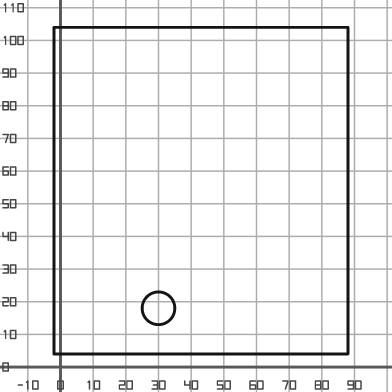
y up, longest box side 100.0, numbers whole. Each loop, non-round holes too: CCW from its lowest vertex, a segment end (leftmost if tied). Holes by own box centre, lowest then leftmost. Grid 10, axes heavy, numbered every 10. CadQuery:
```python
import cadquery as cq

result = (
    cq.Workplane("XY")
    .moveTo(-2.0, 4.0)
    .lineTo(88.0, 4.0)
    .lineTo(88.0, 104.0)
    .lineTo(-2.0, 104.0)
    .close()
    .moveTo(30.0, 18.0)
    .circle(5.0)
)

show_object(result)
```